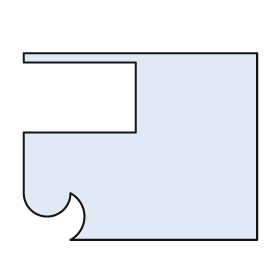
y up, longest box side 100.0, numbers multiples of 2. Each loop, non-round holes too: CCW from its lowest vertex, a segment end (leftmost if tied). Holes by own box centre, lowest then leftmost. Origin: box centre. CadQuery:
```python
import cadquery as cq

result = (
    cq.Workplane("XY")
    .moveTo(-30.0, -40.0)
    .lineTo(50.0, -40.0)
    .lineTo(50.0, 40.0)
    .lineTo(-50.0, 40.0)
    .lineTo(-50.0, 36.0)
    .lineTo(-2.0, 36.0)
    .lineTo(-2.0, 6.0)
    .lineTo(-50.0, 6.0)
    .lineTo(-50.0, -20.0)
    .threePointArc((-40.0, -30.0), (-30.0, -20.0))
    .threePointArc((-24.0, -30.0), (-30.0, -40.0))
    .close()
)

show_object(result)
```